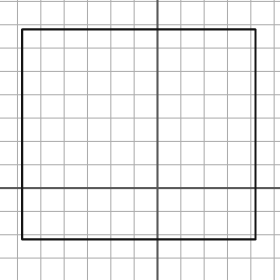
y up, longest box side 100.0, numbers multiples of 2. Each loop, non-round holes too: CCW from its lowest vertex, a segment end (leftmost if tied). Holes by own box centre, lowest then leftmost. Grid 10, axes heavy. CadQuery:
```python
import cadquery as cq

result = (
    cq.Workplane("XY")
    .moveTo(-58.0, -22.0)
    .lineTo(42.0, -22.0)
    .lineTo(42.0, 68.0)
    .lineTo(-58.0, 68.0)
    .close()
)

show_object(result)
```